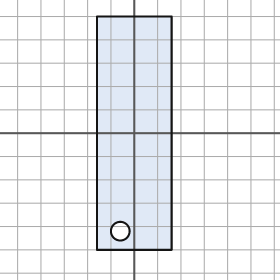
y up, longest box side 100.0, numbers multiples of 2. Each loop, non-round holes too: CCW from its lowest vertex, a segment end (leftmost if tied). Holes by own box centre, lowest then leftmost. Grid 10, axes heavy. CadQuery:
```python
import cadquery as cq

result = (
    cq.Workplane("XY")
    .moveTo(-16.0, -50.0)
    .lineTo(16.0, -50.0)
    .lineTo(16.0, 50.0)
    .lineTo(-16.0, 50.0)
    .close()
    .moveTo(-6.0, -42.0)
    .circle(4.0)
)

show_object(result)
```